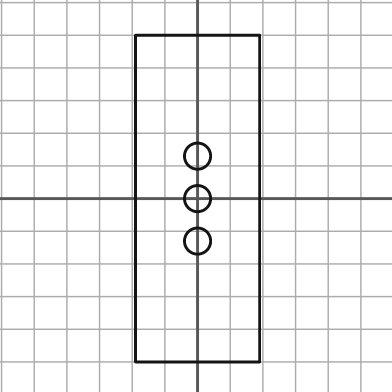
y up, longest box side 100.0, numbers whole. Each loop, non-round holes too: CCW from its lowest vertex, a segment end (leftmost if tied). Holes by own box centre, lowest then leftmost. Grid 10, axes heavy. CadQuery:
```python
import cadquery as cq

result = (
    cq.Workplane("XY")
    .moveTo(-19.0, -50.0)
    .lineTo(19.0, -50.0)
    .lineTo(19.0, 50.0)
    .lineTo(-19.0, 50.0)
    .close()
    .moveTo(0.0, -13.0)
    .circle(4.0)
    .moveTo(0.0, 0.0)
    .circle(4.0)
    .moveTo(0.0, 13.0)
    .circle(4.0)
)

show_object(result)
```